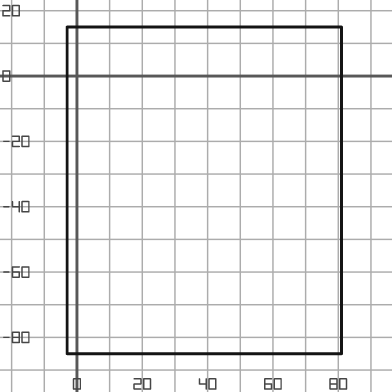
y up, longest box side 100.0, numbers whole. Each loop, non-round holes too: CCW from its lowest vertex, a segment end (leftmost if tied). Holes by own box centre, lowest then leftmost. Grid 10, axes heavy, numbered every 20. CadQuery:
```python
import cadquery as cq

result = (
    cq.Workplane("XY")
    .moveTo(-3.0, -85.0)
    .lineTo(81.0, -85.0)
    .lineTo(81.0, 15.0)
    .lineTo(-3.0, 15.0)
    .close()
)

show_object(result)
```